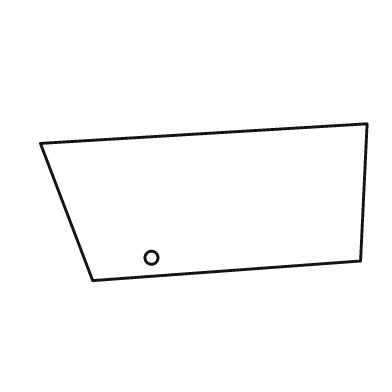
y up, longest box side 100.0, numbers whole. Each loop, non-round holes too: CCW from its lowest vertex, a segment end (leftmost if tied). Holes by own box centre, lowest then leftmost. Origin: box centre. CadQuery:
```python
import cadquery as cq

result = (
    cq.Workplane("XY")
    .moveTo(-34.0, -24.0)
    .lineTo(48.0, -18.0)
    .lineTo(50.0, 24.0)
    .lineTo(-50.0, 18.0)
    .close()
    .moveTo(-16.0, -17.0)
    .circle(2.0)
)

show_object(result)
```